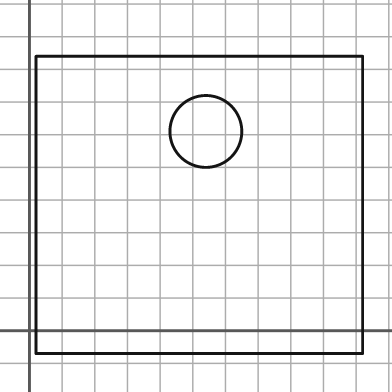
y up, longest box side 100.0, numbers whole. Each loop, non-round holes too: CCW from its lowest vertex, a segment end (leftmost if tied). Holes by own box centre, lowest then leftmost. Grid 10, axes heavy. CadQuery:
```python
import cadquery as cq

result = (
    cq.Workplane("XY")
    .moveTo(2.0, -7.0)
    .lineTo(102.0, -7.0)
    .lineTo(102.0, 84.0)
    .lineTo(2.0, 84.0)
    .close()
    .moveTo(54.0, 61.0)
    .circle(11.0)
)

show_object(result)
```